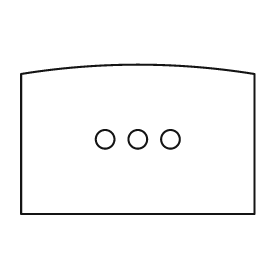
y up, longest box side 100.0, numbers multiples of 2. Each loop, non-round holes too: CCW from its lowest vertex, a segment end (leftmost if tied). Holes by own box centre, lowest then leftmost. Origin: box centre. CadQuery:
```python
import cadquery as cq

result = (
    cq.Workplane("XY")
    .moveTo(-50.0, -32.0)
    .lineTo(50.0, -32.0)
    .lineTo(50.0, 28.0)
    .threePointArc((0.0, 32.0), (-50.0, 28.0))
    .close()
    .moveTo(-14.0, 0.0)
    .circle(4.0)
    .moveTo(0.0, 0.0)
    .circle(4.0)
    .moveTo(14.0, 0.0)
    .circle(4.0)
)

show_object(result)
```